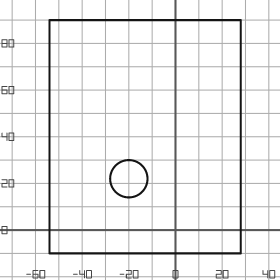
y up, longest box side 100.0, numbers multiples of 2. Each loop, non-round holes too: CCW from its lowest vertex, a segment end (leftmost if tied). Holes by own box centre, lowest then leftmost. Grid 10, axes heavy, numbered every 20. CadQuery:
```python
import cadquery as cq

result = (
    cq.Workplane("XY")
    .moveTo(-54.0, -10.0)
    .lineTo(28.0, -10.0)
    .lineTo(28.0, 90.0)
    .lineTo(-54.0, 90.0)
    .close()
    .moveTo(-20.0, 22.0)
    .circle(8.0)
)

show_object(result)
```